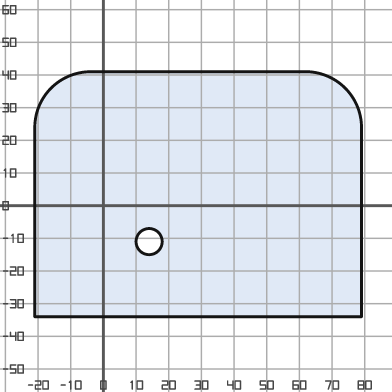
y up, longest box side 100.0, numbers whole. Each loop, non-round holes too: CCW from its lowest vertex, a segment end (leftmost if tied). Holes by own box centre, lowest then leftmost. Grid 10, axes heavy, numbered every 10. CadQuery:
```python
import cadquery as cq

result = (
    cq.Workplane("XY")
    .moveTo(-21.0, -34.0)
    .lineTo(79.0, -34.0)
    .lineTo(79.0, 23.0)
    .threePointArc((74.0, 36.0), (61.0, 41.0))
    .lineTo(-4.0, 41.0)
    .threePointArc((-16.0, 36.0), (-21.0, 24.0))
    .close()
    .moveTo(14.0, -11.0)
    .circle(4.0)
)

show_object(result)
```